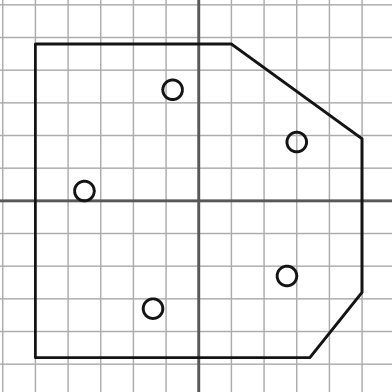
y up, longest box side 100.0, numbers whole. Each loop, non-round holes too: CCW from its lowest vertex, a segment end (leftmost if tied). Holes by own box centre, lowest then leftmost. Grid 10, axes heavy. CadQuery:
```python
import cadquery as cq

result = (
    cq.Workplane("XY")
    .moveTo(-50.0, -48.0)
    .lineTo(34.0, -48.0)
    .lineTo(50.0, -28.0)
    .lineTo(50.0, 19.0)
    .lineTo(10.0, 48.0)
    .lineTo(-50.0, 48.0)
    .close()
    .moveTo(-14.0, -33.0)
    .circle(3.0)
    .moveTo(27.0, -23.0)
    .circle(3.0)
    .moveTo(-35.0, 3.0)
    .circle(3.0)
    .moveTo(30.0, 18.0)
    .circle(3.0)
    .moveTo(-8.0, 34.0)
    .circle(3.0)
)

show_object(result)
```